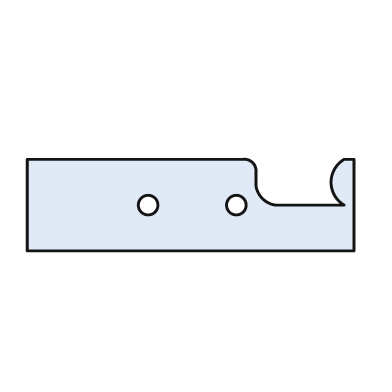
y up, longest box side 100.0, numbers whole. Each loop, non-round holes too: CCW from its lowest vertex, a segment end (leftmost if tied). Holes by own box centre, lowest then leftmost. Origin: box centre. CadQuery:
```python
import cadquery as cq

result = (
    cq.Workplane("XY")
    .moveTo(-50.0, -14.0)
    .lineTo(50.0, -14.0)
    .lineTo(50.0, 14.0)
    .lineTo(47.0, 14.0)
    .threePointArc((43.0, 7.0), (47.0, 0.0))
    .lineTo(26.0, 0.0)
    .threePointArc((22.0, 2.0), (20.0, 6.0))
    .lineTo(20.0, 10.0)
    .threePointArc((19.0, 13.0), (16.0, 14.0))
    .lineTo(-50.0, 14.0)
    .close()
    .moveTo(-13.0, 0.0)
    .circle(3.0)
    .moveTo(14.0, 0.0)
    .circle(3.0)
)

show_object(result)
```